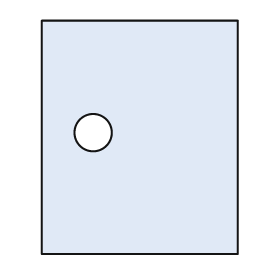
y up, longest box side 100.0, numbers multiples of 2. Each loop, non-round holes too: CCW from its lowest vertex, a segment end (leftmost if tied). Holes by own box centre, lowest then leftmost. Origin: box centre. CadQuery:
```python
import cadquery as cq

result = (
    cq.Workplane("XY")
    .moveTo(-42.0, -50.0)
    .lineTo(42.0, -50.0)
    .lineTo(42.0, 50.0)
    .lineTo(-42.0, 50.0)
    .close()
    .moveTo(-20.0, 2.0)
    .circle(8.0)
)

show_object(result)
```